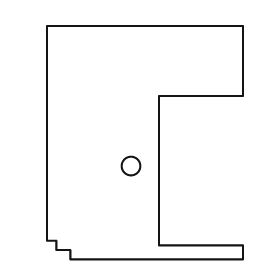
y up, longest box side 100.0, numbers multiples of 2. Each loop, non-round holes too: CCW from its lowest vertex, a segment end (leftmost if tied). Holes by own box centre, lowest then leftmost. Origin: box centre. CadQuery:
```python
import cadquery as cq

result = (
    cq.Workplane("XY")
    .moveTo(-32.0, -50.0)
    .lineTo(42.0, -50.0)
    .lineTo(42.0, -44.0)
    .lineTo(6.0, -44.0)
    .lineTo(6.0, 20.0)
    .lineTo(42.0, 20.0)
    .lineTo(42.0, 50.0)
    .lineTo(-42.0, 50.0)
    .lineTo(-42.0, -42.0)
    .lineTo(-38.0, -42.0)
    .lineTo(-38.0, -46.0)
    .lineTo(-32.0, -46.0)
    .close()
    .moveTo(-6.0, -10.0)
    .circle(4.0)
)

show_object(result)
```